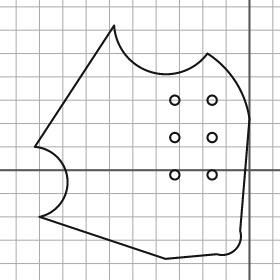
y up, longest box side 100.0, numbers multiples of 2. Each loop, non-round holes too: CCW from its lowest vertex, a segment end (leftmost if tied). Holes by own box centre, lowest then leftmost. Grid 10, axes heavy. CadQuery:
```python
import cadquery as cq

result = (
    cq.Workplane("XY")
    .moveTo(-36.0, -38.0)
    .lineTo(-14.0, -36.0)
    .threePointArc((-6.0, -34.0), (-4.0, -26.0))
    .lineTo(0.0, 22.0)
    .threePointArc((-6.0, 38.0), (-18.0, 50.0))
    .threePointArc((-42.0, 42.0), (-58.0, 62.0))
    .lineTo(-92.0, 10.0)
    .threePointArc((-78.0, -4.0), (-90.0, -20.0))
    .close()
    .moveTo(-32.0, -2.0)
    .circle(2.0)
    .moveTo(-16.0, -2.0)
    .circle(2.0)
    .moveTo(-32.0, 14.0)
    .circle(2.0)
    .moveTo(-16.0, 14.0)
    .circle(2.0)
    .moveTo(-32.0, 30.0)
    .circle(2.0)
    .moveTo(-16.0, 30.0)
    .circle(2.0)
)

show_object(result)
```